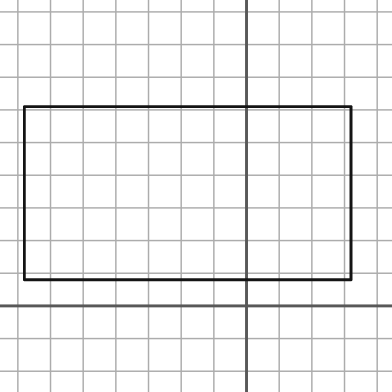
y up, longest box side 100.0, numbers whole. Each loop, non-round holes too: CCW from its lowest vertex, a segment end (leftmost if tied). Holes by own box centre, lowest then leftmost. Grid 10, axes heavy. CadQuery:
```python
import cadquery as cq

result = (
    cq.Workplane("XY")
    .moveTo(-68.0, 8.0)
    .lineTo(32.0, 8.0)
    .lineTo(32.0, 61.0)
    .lineTo(-68.0, 61.0)
    .close()
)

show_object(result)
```